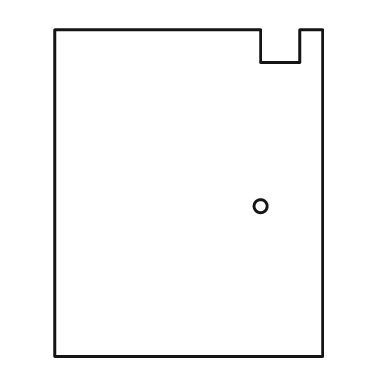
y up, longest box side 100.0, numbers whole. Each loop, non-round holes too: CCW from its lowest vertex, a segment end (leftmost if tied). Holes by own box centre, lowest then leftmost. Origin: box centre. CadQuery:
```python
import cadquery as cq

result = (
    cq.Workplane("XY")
    .moveTo(-41.0, -50.0)
    .lineTo(41.0, -50.0)
    .lineTo(41.0, 50.0)
    .lineTo(34.0, 50.0)
    .lineTo(34.0, 40.0)
    .lineTo(22.0, 40.0)
    .lineTo(22.0, 50.0)
    .lineTo(-41.0, 50.0)
    .close()
    .moveTo(22.0, -4.0)
    .circle(2.0)
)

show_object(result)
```